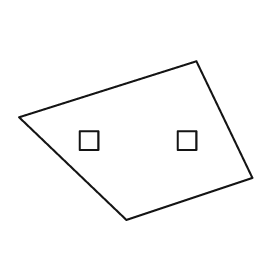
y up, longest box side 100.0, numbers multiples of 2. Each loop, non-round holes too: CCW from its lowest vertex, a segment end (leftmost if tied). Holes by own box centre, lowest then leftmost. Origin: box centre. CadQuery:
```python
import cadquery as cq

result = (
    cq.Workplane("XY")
    .moveTo(-4.0, -34.0)
    .lineTo(50.0, -16.0)
    .lineTo(26.0, 34.0)
    .lineTo(-50.0, 10.0)
    .close()
    .moveTo(-24.0, -4.0)
    .lineTo(-16.0, -4.0)
    .lineTo(-16.0, 4.0)
    .lineTo(-24.0, 4.0)
    .close()
    .moveTo(18.0, -4.0)
    .lineTo(26.0, -4.0)
    .lineTo(26.0, 4.0)
    .lineTo(18.0, 4.0)
    .close()
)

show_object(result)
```